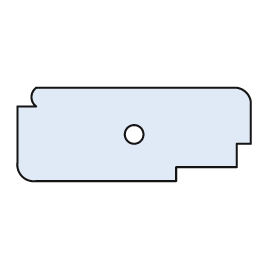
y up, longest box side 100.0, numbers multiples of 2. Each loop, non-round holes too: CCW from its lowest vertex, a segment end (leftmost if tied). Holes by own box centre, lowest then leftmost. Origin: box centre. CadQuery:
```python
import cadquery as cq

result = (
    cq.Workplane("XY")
    .moveTo(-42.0, -20.0)
    .lineTo(18.0, -20.0)
    .lineTo(18.0, -14.0)
    .lineTo(44.0, -14.0)
    .lineTo(44.0, -4.0)
    .lineTo(50.0, -4.0)
    .lineTo(50.0, 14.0)
    .threePointArc((48.0, 18.0), (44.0, 20.0))
    .lineTo(-42.0, 20.0)
    .threePointArc((-44.0, 16.0), (-42.0, 12.0))
    .lineTo(-50.0, 12.0)
    .lineTo(-50.0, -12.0)
    .threePointArc((-48.0, -18.0), (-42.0, -20.0))
    .close()
    .moveTo(0.0, 0.0)
    .circle(4.0)
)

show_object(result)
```